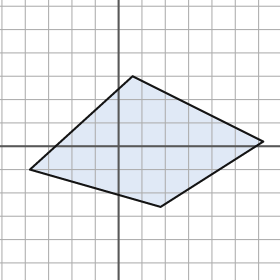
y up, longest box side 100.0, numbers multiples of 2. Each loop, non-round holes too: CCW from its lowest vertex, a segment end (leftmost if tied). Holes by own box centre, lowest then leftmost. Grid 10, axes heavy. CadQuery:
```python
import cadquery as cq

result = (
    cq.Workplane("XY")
    .moveTo(18.0, -26.0)
    .lineTo(62.0, 2.0)
    .lineTo(6.0, 30.0)
    .lineTo(-38.0, -10.0)
    .close()
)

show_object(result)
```